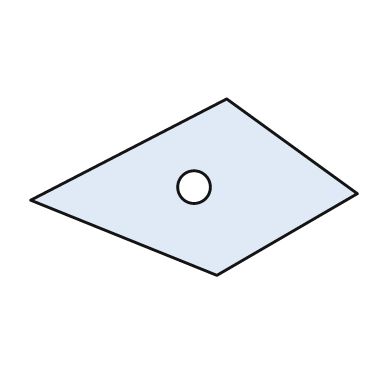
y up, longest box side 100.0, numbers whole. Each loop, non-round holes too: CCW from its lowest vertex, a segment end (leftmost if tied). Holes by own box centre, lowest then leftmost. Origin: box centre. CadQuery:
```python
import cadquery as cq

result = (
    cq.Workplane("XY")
    .moveTo(7.0, -27.0)
    .lineTo(50.0, -2.0)
    .lineTo(10.0, 27.0)
    .lineTo(-50.0, -4.0)
    .close()
    .moveTo(0.0, 0.0)
    .circle(5.0)
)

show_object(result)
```